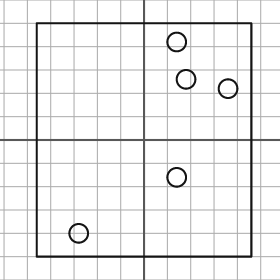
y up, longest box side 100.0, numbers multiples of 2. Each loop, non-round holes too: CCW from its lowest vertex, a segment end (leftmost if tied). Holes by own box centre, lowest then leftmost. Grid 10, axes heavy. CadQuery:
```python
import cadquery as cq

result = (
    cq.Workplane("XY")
    .moveTo(-46.0, -50.0)
    .lineTo(46.0, -50.0)
    .lineTo(46.0, 50.0)
    .lineTo(-46.0, 50.0)
    .close()
    .moveTo(-28.0, -40.0)
    .circle(4.0)
    .moveTo(14.0, -16.0)
    .circle(4.0)
    .moveTo(36.0, 22.0)
    .circle(4.0)
    .moveTo(18.0, 26.0)
    .circle(4.0)
    .moveTo(14.0, 42.0)
    .circle(4.0)
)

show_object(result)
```